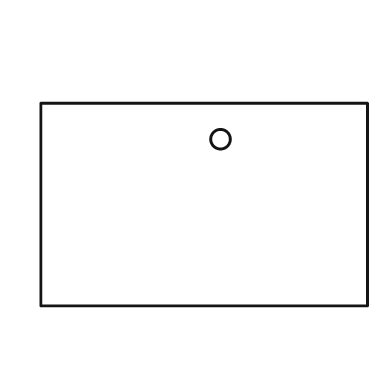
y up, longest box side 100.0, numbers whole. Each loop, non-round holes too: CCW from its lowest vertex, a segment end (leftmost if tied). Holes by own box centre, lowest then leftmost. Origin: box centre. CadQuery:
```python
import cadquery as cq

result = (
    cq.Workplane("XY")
    .moveTo(-50.0, -31.0)
    .lineTo(50.0, -31.0)
    .lineTo(50.0, 31.0)
    .lineTo(-50.0, 31.0)
    .close()
    .moveTo(5.0, 20.0)
    .circle(3.0)
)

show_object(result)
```